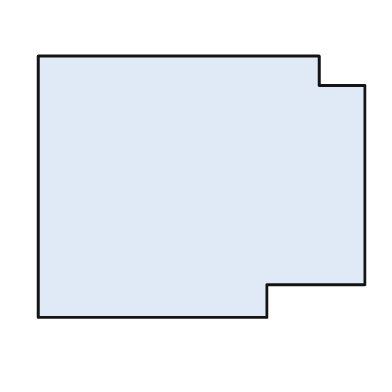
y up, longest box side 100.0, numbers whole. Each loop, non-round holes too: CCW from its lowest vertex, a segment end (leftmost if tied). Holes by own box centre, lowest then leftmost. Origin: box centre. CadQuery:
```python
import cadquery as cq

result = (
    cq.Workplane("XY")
    .moveTo(-50.0, -40.0)
    .lineTo(20.0, -40.0)
    .lineTo(20.0, -30.0)
    .lineTo(50.0, -30.0)
    .lineTo(50.0, 31.0)
    .lineTo(36.0, 31.0)
    .lineTo(36.0, 40.0)
    .lineTo(-50.0, 40.0)
    .close()
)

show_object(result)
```